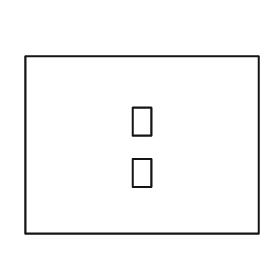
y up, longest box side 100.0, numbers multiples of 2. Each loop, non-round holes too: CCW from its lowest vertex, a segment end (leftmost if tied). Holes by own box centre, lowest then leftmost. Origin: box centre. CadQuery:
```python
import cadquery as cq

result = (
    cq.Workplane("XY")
    .moveTo(-50.0, -38.0)
    .lineTo(50.0, -38.0)
    .lineTo(50.0, 38.0)
    .lineTo(-50.0, 38.0)
    .close()
    .moveTo(-4.0, -18.0)
    .lineTo(4.0, -18.0)
    .lineTo(4.0, -6.0)
    .lineTo(-4.0, -6.0)
    .close()
    .moveTo(-4.0, 4.0)
    .lineTo(4.0, 4.0)
    .lineTo(4.0, 16.0)
    .lineTo(-4.0, 16.0)
    .close()
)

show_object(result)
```